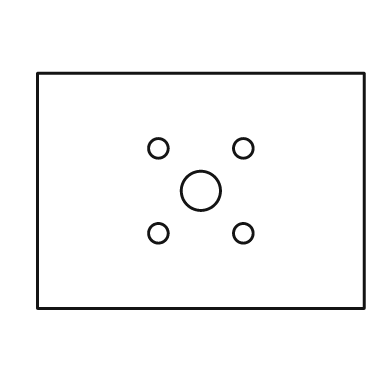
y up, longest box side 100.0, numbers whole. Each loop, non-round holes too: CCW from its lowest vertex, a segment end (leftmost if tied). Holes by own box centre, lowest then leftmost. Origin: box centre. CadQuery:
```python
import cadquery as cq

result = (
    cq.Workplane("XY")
    .moveTo(-50.0, -36.0)
    .lineTo(50.0, -36.0)
    .lineTo(50.0, 36.0)
    .lineTo(-50.0, 36.0)
    .close()
    .moveTo(-13.0, -13.0)
    .circle(3.0)
    .moveTo(13.0, -13.0)
    .circle(3.0)
    .moveTo(0.0, 0.0)
    .circle(6.0)
    .moveTo(-13.0, 13.0)
    .circle(3.0)
    .moveTo(13.0, 13.0)
    .circle(3.0)
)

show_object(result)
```